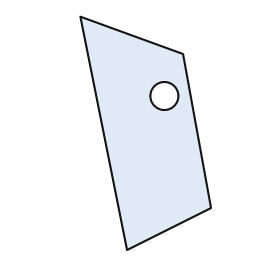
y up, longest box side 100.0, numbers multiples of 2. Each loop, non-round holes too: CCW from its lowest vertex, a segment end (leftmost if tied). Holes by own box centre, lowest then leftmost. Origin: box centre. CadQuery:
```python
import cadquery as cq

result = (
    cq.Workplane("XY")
    .moveTo(-8.0, -50.0)
    .lineTo(28.0, -32.0)
    .lineTo(16.0, 34.0)
    .lineTo(-28.0, 50.0)
    .close()
    .moveTo(8.0, 16.0)
    .circle(6.0)
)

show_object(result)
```